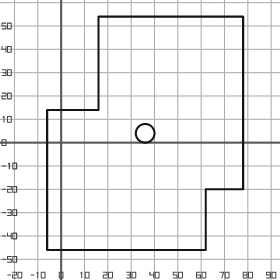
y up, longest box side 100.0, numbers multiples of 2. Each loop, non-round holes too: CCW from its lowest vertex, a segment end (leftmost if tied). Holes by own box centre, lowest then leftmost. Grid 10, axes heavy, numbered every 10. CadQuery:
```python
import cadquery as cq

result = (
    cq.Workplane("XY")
    .moveTo(-6.0, -46.0)
    .lineTo(62.0, -46.0)
    .lineTo(62.0, -20.0)
    .lineTo(78.0, -20.0)
    .lineTo(78.0, 54.0)
    .lineTo(16.0, 54.0)
    .lineTo(16.0, 14.0)
    .lineTo(-6.0, 14.0)
    .close()
    .moveTo(36.0, 4.0)
    .circle(4.0)
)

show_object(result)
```